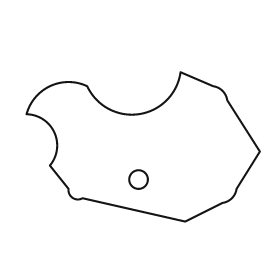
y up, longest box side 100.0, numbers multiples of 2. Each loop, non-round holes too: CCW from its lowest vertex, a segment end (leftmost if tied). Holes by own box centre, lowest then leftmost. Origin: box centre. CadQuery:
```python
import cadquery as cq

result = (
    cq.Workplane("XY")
    .moveTo(18.0, -32.0)
    .lineTo(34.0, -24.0)
    .threePointArc((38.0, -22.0), (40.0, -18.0))
    .lineTo(50.0, -2.0)
    .lineTo(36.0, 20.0)
    .threePointArc((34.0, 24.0), (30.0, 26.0))
    .lineTo(16.0, 32.0)
    .threePointArc((-2.0, 14.0), (-24.0, 26.0))
    .threePointArc((-40.0, 26.0), (-50.0, 14.0))
    .threePointArc((-38.0, 6.0), (-40.0, -8.0))
    .lineTo(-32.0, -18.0)
    .threePointArc((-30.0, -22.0), (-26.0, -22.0))
    .close()
    .moveTo(-2.0, -14.0)
    .circle(4.0)
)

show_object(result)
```